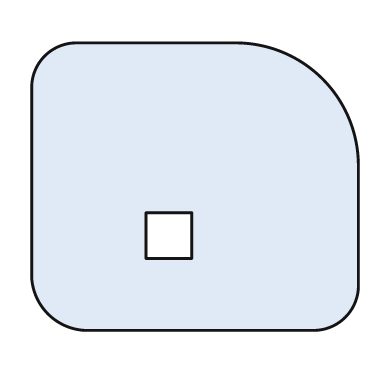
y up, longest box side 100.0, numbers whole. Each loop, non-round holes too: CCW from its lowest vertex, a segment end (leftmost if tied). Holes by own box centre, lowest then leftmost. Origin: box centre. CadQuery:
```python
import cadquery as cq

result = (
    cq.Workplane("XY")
    .moveTo(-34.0, -44.0)
    .lineTo(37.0, -44.0)
    .threePointArc((46.0, -40.0), (50.0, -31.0))
    .lineTo(50.0, 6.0)
    .threePointArc((39.0, 33.0), (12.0, 44.0))
    .lineTo(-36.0, 44.0)
    .threePointArc((-46.0, 40.0), (-50.0, 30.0))
    .lineTo(-50.0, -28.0)
    .threePointArc((-45.0, -39.0), (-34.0, -44.0))
    .close()
    .moveTo(-15.0, -22.0)
    .lineTo(-1.0, -22.0)
    .lineTo(-1.0, -8.0)
    .lineTo(-15.0, -8.0)
    .close()
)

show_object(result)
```